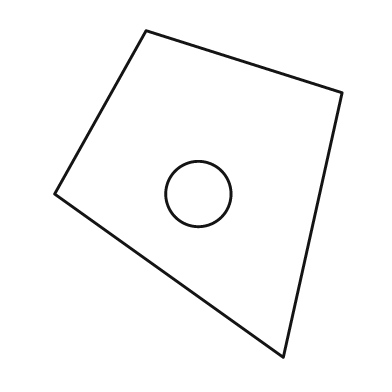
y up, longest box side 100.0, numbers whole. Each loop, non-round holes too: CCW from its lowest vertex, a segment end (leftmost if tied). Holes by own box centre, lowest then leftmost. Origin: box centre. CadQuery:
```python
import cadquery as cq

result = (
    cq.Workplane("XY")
    .moveTo(26.0, -50.0)
    .lineTo(44.0, 31.0)
    .lineTo(-16.0, 50.0)
    .lineTo(-44.0, 0.0)
    .close()
    .moveTo(0.0, 0.0)
    .circle(10.0)
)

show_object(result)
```